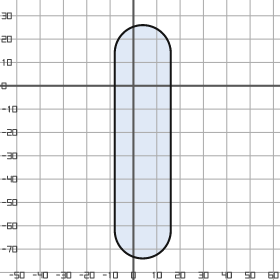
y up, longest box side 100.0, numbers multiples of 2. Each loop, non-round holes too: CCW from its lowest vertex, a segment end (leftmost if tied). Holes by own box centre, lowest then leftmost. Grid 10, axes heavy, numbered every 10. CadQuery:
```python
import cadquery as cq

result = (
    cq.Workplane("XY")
    .moveTo(-8.0, -62.0)
    .threePointArc((4.0, -74.0), (16.0, -62.0))
    .lineTo(16.0, 14.0)
    .threePointArc((4.0, 26.0), (-8.0, 14.0))
    .close()
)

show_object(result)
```